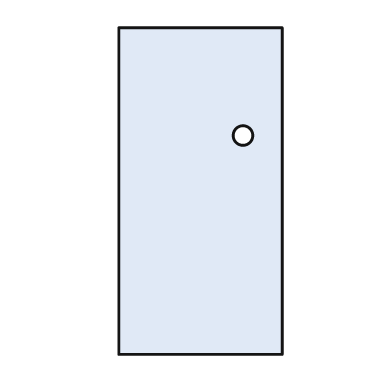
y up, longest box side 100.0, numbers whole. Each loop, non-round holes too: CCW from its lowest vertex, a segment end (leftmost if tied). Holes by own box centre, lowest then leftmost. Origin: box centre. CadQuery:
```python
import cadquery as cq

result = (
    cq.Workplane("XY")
    .moveTo(-25.0, -50.0)
    .lineTo(25.0, -50.0)
    .lineTo(25.0, 50.0)
    .lineTo(-25.0, 50.0)
    .close()
    .moveTo(13.0, 17.0)
    .circle(3.0)
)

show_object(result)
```